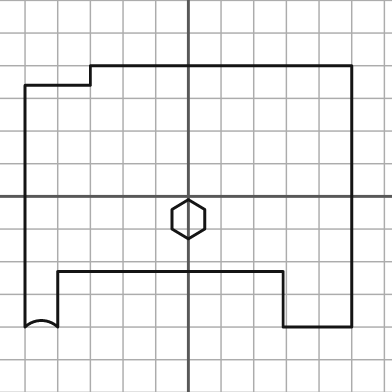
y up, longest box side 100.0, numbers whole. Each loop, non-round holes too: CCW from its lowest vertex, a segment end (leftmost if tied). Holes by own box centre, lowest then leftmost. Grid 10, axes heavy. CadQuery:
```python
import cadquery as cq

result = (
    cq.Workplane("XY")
    .moveTo(-50.0, -40.0)
    .threePointArc((-45.0, -38.0), (-40.0, -40.0))
    .lineTo(-40.0, -23.0)
    .lineTo(29.0, -23.0)
    .lineTo(29.0, -40.0)
    .lineTo(50.0, -40.0)
    .lineTo(50.0, 40.0)
    .lineTo(-30.0, 40.0)
    .lineTo(-30.0, 34.0)
    .lineTo(-50.0, 34.0)
    .close()
    .moveTo(0.0, -13.0)
    .lineTo(5.0, -10.0)
    .lineTo(5.0, -4.0)
    .lineTo(0.0, -1.0)
    .lineTo(-5.0, -4.0)
    .lineTo(-5.0, -10.0)
    .close()
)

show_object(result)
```